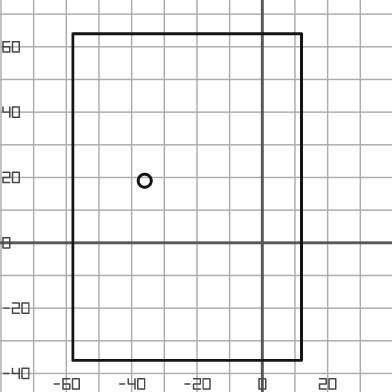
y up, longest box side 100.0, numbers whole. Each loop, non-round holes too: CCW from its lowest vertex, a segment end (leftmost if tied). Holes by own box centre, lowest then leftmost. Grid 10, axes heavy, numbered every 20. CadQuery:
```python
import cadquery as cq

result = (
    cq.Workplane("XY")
    .moveTo(-58.0, -36.0)
    .lineTo(12.0, -36.0)
    .lineTo(12.0, 64.0)
    .lineTo(-58.0, 64.0)
    .close()
    .moveTo(-36.0, 19.0)
    .circle(2.0)
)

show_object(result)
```